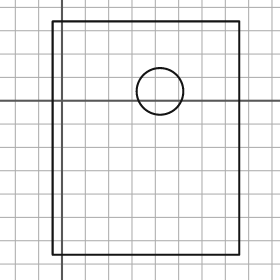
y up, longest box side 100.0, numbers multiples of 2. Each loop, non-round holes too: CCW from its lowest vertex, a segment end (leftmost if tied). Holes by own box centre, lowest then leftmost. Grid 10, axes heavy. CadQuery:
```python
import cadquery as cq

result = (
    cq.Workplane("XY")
    .moveTo(-4.0, -66.0)
    .lineTo(76.0, -66.0)
    .lineTo(76.0, 34.0)
    .lineTo(-4.0, 34.0)
    .close()
    .moveTo(42.0, 4.0)
    .circle(10.0)
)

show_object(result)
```